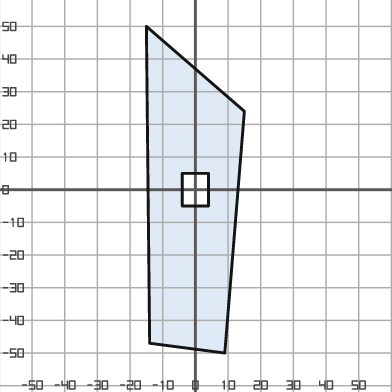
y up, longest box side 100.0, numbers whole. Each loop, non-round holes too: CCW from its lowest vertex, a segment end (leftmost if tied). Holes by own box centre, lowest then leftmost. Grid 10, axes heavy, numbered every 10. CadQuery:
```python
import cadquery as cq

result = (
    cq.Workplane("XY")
    .moveTo(9.0, -50.0)
    .lineTo(15.0, 24.0)
    .lineTo(-15.0, 50.0)
    .lineTo(-14.0, -47.0)
    .close()
    .moveTo(-4.0, -5.0)
    .lineTo(4.0, -5.0)
    .lineTo(4.0, 5.0)
    .lineTo(-4.0, 5.0)
    .close()
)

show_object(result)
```